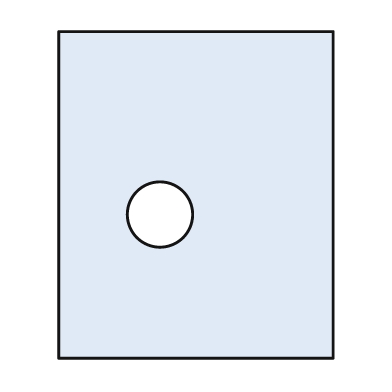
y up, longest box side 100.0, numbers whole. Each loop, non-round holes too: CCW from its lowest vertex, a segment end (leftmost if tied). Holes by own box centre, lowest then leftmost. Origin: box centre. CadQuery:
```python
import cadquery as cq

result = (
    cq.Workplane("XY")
    .moveTo(-42.0, -50.0)
    .lineTo(42.0, -50.0)
    .lineTo(42.0, 50.0)
    .lineTo(-42.0, 50.0)
    .close()
    .moveTo(-11.0, -6.0)
    .circle(10.0)
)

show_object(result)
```